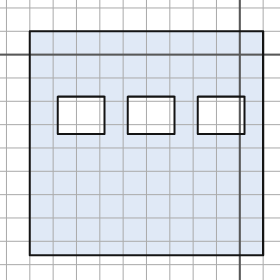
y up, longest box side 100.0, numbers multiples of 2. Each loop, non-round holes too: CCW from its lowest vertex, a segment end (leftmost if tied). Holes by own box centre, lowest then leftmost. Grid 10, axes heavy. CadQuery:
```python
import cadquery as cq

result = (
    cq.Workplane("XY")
    .moveTo(-90.0, -86.0)
    .lineTo(10.0, -86.0)
    .lineTo(10.0, 10.0)
    .lineTo(-90.0, 10.0)
    .close()
    .moveTo(-78.0, -34.0)
    .lineTo(-58.0, -34.0)
    .lineTo(-58.0, -18.0)
    .lineTo(-78.0, -18.0)
    .close()
    .moveTo(-48.0, -34.0)
    .lineTo(-28.0, -34.0)
    .lineTo(-28.0, -18.0)
    .lineTo(-48.0, -18.0)
    .close()
    .moveTo(-18.0, -34.0)
    .lineTo(2.0, -34.0)
    .lineTo(2.0, -18.0)
    .lineTo(-18.0, -18.0)
    .close()
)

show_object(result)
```